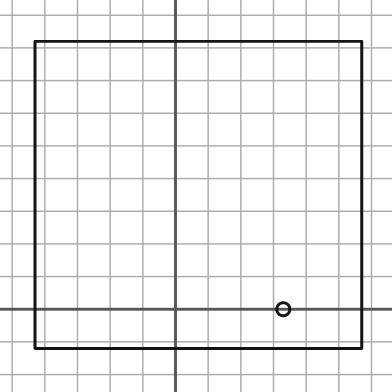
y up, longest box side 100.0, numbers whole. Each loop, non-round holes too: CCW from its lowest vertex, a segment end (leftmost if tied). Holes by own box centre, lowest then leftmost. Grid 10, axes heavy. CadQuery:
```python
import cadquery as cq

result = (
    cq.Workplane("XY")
    .moveTo(-43.0, -12.0)
    .lineTo(57.0, -12.0)
    .lineTo(57.0, 82.0)
    .lineTo(-43.0, 82.0)
    .close()
    .moveTo(33.0, 0.0)
    .circle(2.0)
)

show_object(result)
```